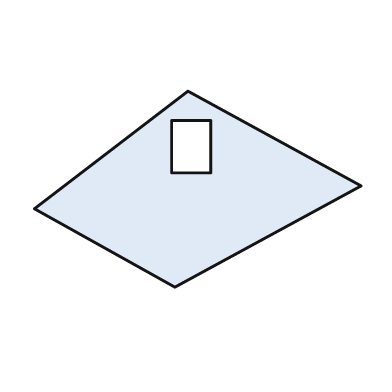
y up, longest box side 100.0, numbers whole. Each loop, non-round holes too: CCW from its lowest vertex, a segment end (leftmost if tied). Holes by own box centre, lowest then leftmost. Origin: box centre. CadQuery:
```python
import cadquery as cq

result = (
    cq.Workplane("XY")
    .moveTo(-7.0, -30.0)
    .lineTo(50.0, 1.0)
    .lineTo(-3.0, 30.0)
    .lineTo(-50.0, -6.0)
    .close()
    .moveTo(-8.0, 5.0)
    .lineTo(4.0, 5.0)
    .lineTo(4.0, 21.0)
    .lineTo(-8.0, 21.0)
    .close()
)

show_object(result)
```